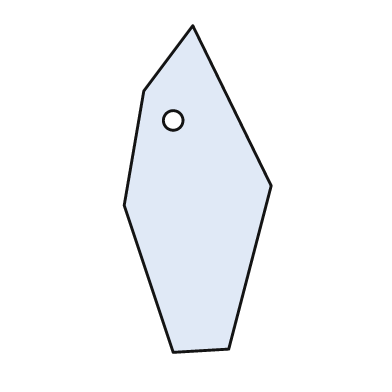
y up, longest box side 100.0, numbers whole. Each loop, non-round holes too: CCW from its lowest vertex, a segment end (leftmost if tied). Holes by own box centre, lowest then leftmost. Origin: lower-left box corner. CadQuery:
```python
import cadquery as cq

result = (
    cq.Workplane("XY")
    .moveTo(15.0, 0.0)
    .lineTo(32.0, 1.0)
    .lineTo(45.0, 51.0)
    .lineTo(21.0, 100.0)
    .lineTo(6.0, 80.0)
    .lineTo(0.0, 45.0)
    .close()
    .moveTo(15.0, 71.0)
    .circle(3.0)
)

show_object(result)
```